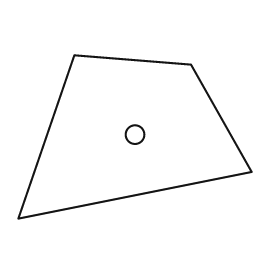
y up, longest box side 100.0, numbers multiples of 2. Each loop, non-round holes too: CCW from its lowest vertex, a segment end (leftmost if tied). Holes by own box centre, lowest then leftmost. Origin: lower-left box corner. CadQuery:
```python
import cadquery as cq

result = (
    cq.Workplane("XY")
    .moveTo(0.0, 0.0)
    .lineTo(100.0, 20.0)
    .lineTo(74.0, 66.0)
    .lineTo(24.0, 70.0)
    .close()
    .moveTo(50.0, 36.0)
    .circle(4.0)
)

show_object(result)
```